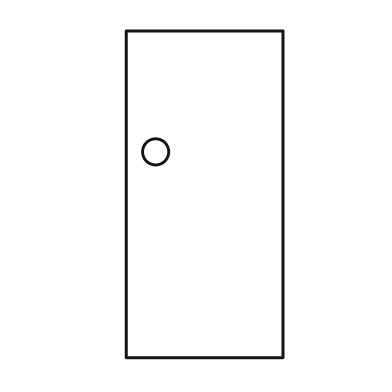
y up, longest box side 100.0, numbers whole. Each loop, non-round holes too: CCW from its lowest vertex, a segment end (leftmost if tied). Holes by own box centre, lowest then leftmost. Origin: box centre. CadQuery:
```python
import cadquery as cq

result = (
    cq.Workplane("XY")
    .moveTo(-24.0, -50.0)
    .lineTo(24.0, -50.0)
    .lineTo(24.0, 50.0)
    .lineTo(-24.0, 50.0)
    .close()
    .moveTo(-15.0, 13.0)
    .circle(4.0)
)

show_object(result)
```